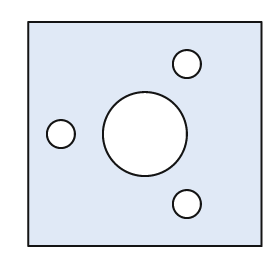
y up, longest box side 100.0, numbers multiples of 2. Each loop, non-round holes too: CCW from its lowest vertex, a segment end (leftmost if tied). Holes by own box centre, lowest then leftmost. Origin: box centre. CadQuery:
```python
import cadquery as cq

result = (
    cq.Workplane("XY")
    .moveTo(-50.0, -48.0)
    .lineTo(50.0, -48.0)
    .lineTo(50.0, 48.0)
    .lineTo(-50.0, 48.0)
    .close()
    .moveTo(18.0, -30.0)
    .circle(6.0)
    .moveTo(-36.0, 0.0)
    .circle(6.0)
    .moveTo(0.0, 0.0)
    .circle(18.0)
    .moveTo(18.0, 30.0)
    .circle(6.0)
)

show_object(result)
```